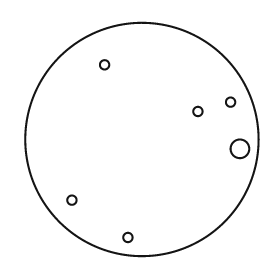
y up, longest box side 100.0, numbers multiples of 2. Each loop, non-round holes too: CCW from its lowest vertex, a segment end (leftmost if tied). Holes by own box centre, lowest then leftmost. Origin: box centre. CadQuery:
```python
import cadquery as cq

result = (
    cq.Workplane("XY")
    .moveTo(0.0, 0.0)
    .circle(50.0)
    .moveTo(-6.0, -42.0)
    .circle(2.0)
    .moveTo(-30.0, -26.0)
    .circle(2.0)
    .moveTo(42.0, -4.0)
    .circle(4.0)
    .moveTo(24.0, 12.0)
    .circle(2.0)
    .moveTo(38.0, 16.0)
    .circle(2.0)
    .moveTo(-16.0, 32.0)
    .circle(2.0)
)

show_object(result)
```